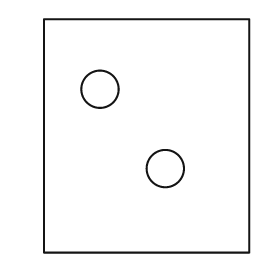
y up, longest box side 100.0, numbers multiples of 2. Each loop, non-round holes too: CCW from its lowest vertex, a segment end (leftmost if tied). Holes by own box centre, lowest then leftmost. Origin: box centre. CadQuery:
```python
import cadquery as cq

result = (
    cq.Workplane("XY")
    .moveTo(-44.0, -50.0)
    .lineTo(44.0, -50.0)
    .lineTo(44.0, 50.0)
    .lineTo(-44.0, 50.0)
    .close()
    .moveTo(8.0, -14.0)
    .circle(8.0)
    .moveTo(-20.0, 20.0)
    .circle(8.0)
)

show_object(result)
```